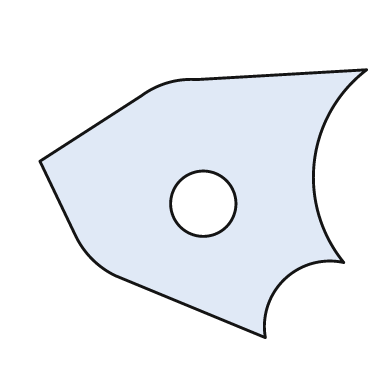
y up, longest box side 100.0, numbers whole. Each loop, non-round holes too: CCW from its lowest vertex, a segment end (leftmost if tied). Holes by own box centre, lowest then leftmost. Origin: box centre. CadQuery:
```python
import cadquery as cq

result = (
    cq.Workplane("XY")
    .moveTo(19.0, -41.0)
    .threePointArc((25.0, -23.0), (43.0, -18.0))
    .threePointArc((34.0, 13.0), (50.0, 41.0))
    .lineTo(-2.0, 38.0)
    .threePointArc((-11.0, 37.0), (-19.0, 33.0))
    .lineTo(-50.0, 13.0)
    .lineTo(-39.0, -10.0)
    .threePointArc((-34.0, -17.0), (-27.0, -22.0))
    .close()
    .moveTo(0.0, 0.0)
    .circle(10.0)
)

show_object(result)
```